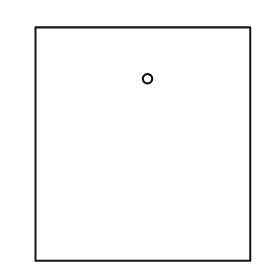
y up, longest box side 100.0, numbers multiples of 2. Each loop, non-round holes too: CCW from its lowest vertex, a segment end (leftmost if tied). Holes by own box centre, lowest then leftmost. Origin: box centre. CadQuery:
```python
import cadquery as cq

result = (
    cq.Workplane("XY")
    .moveTo(-46.0, -50.0)
    .lineTo(46.0, -50.0)
    .lineTo(46.0, 50.0)
    .lineTo(-46.0, 50.0)
    .close()
    .moveTo(2.0, 28.0)
    .circle(2.0)
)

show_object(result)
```